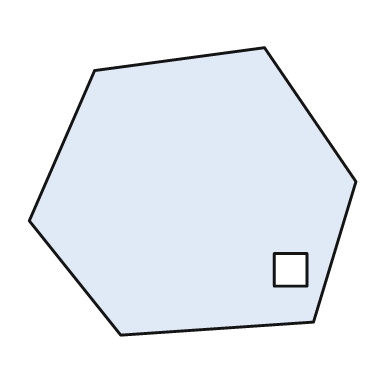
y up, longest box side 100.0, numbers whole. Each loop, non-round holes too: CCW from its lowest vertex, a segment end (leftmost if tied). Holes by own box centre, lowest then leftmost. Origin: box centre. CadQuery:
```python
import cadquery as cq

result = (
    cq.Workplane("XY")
    .moveTo(-22.0, -44.0)
    .lineTo(37.0, -40.0)
    .lineTo(50.0, 3.0)
    .lineTo(22.0, 44.0)
    .lineTo(-30.0, 37.0)
    .lineTo(-50.0, -9.0)
    .close()
    .moveTo(25.0, -29.0)
    .lineTo(35.0, -29.0)
    .lineTo(35.0, -19.0)
    .lineTo(25.0, -19.0)
    .close()
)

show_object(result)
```